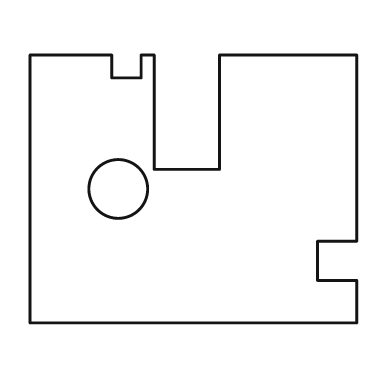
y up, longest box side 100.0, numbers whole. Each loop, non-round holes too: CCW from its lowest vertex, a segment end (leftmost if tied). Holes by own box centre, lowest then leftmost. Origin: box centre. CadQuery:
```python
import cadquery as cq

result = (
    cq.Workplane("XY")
    .moveTo(-50.0, -41.0)
    .lineTo(50.0, -41.0)
    .lineTo(50.0, -28.0)
    .lineTo(38.0, -28.0)
    .lineTo(38.0, -16.0)
    .lineTo(50.0, -16.0)
    .lineTo(50.0, 41.0)
    .lineTo(8.0, 41.0)
    .lineTo(8.0, 6.0)
    .lineTo(-12.0, 6.0)
    .lineTo(-12.0, 41.0)
    .lineTo(-16.0, 41.0)
    .lineTo(-16.0, 34.0)
    .lineTo(-25.0, 34.0)
    .lineTo(-25.0, 41.0)
    .lineTo(-50.0, 41.0)
    .close()
    .moveTo(-23.0, 0.0)
    .circle(9.0)
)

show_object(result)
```